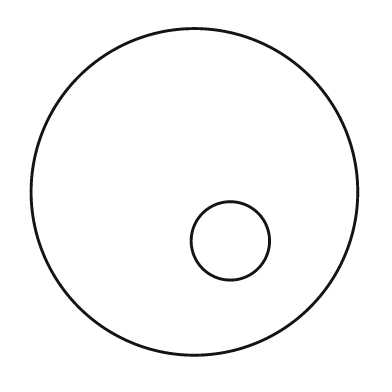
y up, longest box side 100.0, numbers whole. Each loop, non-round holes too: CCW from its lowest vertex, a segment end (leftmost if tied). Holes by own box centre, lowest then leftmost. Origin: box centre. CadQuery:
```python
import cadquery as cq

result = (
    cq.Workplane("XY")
    .moveTo(0.0, 0.0)
    .circle(50.0)
    .moveTo(11.0, -15.0)
    .circle(12.0)
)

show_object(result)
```